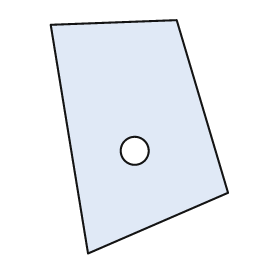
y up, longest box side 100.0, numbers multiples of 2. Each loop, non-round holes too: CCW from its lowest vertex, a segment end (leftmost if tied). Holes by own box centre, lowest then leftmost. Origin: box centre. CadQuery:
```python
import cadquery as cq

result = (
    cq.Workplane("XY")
    .moveTo(-22.0, -50.0)
    .lineTo(38.0, -24.0)
    .lineTo(16.0, 50.0)
    .lineTo(-38.0, 48.0)
    .close()
    .moveTo(-2.0, -6.0)
    .circle(6.0)
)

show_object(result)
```